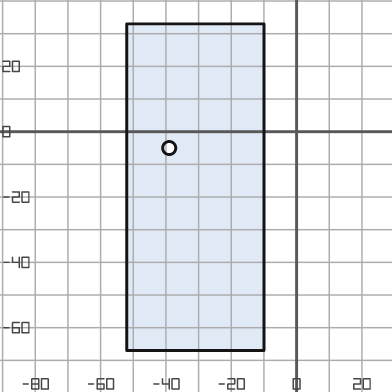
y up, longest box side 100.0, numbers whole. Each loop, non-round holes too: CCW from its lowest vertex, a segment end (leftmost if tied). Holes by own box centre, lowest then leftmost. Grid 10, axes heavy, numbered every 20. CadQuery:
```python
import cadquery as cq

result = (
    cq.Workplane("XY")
    .moveTo(-52.0, -67.0)
    .lineTo(-10.0, -67.0)
    .lineTo(-10.0, 33.0)
    .lineTo(-52.0, 33.0)
    .close()
    .moveTo(-39.0, -5.0)
    .circle(2.0)
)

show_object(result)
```